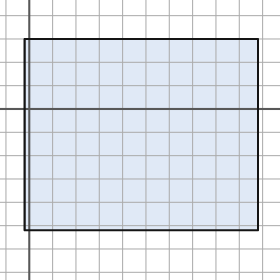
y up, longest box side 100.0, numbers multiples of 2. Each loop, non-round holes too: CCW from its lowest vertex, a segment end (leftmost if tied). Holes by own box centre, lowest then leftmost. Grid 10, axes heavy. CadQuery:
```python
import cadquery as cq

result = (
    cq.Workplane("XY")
    .moveTo(-2.0, -52.0)
    .lineTo(98.0, -52.0)
    .lineTo(98.0, 30.0)
    .lineTo(-2.0, 30.0)
    .close()
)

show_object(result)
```